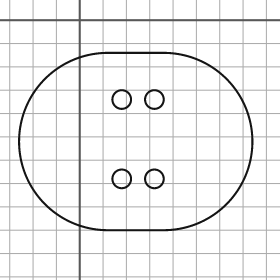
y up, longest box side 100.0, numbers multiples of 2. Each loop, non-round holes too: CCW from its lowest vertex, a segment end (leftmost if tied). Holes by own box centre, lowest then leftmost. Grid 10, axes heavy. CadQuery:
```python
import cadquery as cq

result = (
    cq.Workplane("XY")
    .moveTo(12.0, -90.0)
    .lineTo(36.0, -90.0)
    .threePointArc((74.0, -52.0), (36.0, -14.0))
    .lineTo(12.0, -14.0)
    .threePointArc((-26.0, -52.0), (12.0, -90.0))
    .close()
    .moveTo(18.0, -68.0)
    .circle(4.0)
    .moveTo(32.0, -68.0)
    .circle(4.0)
    .moveTo(18.0, -34.0)
    .circle(4.0)
    .moveTo(32.0, -34.0)
    .circle(4.0)
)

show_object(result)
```